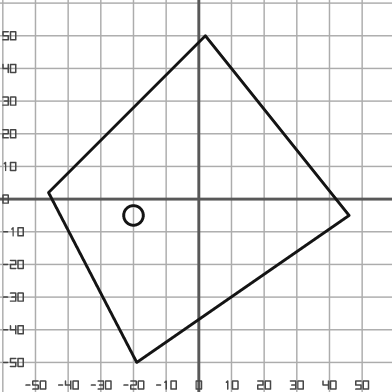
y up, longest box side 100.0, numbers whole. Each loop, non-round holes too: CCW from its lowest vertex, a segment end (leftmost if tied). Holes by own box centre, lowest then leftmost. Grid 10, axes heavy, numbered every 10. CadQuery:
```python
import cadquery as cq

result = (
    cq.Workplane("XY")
    .moveTo(-19.0, -50.0)
    .lineTo(46.0, -5.0)
    .lineTo(2.0, 50.0)
    .lineTo(-46.0, 2.0)
    .close()
    .moveTo(-20.0, -5.0)
    .circle(3.0)
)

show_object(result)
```